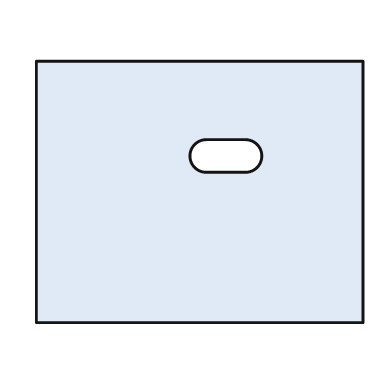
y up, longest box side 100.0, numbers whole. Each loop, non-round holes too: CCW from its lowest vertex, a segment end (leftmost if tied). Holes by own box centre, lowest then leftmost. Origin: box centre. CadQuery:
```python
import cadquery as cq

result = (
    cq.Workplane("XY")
    .moveTo(-50.0, -40.0)
    .lineTo(50.0, -40.0)
    .lineTo(50.0, 40.0)
    .lineTo(-50.0, 40.0)
    .close()
    .moveTo(2.0, 6.0)
    .lineTo(14.0, 6.0)
    .threePointArc((19.0, 11.0), (14.0, 16.0))
    .lineTo(2.0, 16.0)
    .threePointArc((-3.0, 11.0), (2.0, 6.0))
    .close()
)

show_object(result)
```